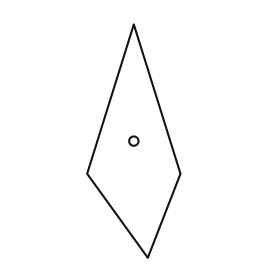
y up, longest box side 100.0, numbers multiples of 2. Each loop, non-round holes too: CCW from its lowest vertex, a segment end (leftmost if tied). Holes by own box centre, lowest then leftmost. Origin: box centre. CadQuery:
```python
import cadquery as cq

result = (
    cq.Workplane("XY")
    .moveTo(6.0, -50.0)
    .lineTo(20.0, -14.0)
    .lineTo(0.0, 50.0)
    .lineTo(-20.0, -14.0)
    .close()
    .moveTo(0.0, 0.0)
    .circle(2.0)
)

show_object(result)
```